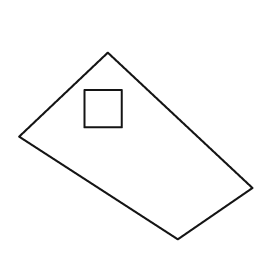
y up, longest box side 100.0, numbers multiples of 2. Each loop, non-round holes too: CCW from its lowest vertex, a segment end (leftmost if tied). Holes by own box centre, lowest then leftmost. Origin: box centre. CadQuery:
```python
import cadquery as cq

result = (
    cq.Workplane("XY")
    .moveTo(18.0, -40.0)
    .lineTo(50.0, -18.0)
    .lineTo(-12.0, 40.0)
    .lineTo(-50.0, 4.0)
    .close()
    .moveTo(-22.0, 8.0)
    .lineTo(-6.0, 8.0)
    .lineTo(-6.0, 24.0)
    .lineTo(-22.0, 24.0)
    .close()
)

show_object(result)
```